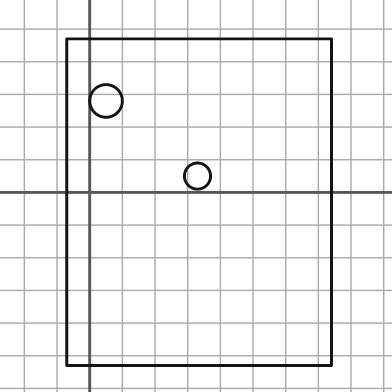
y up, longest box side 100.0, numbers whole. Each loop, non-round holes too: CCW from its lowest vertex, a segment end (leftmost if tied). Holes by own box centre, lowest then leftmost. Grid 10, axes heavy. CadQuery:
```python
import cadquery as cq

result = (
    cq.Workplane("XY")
    .moveTo(-7.0, -53.0)
    .lineTo(74.0, -53.0)
    .lineTo(74.0, 47.0)
    .lineTo(-7.0, 47.0)
    .close()
    .moveTo(33.0, 5.0)
    .circle(4.0)
    .moveTo(5.0, 28.0)
    .circle(5.0)
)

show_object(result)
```